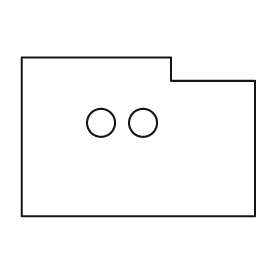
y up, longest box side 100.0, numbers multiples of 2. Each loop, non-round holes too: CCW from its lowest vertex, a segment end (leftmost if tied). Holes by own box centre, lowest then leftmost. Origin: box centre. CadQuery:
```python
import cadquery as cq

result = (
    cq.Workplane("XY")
    .moveTo(-50.0, -34.0)
    .lineTo(50.0, -34.0)
    .lineTo(50.0, 24.0)
    .lineTo(14.0, 24.0)
    .lineTo(14.0, 34.0)
    .lineTo(-50.0, 34.0)
    .close()
    .moveTo(-16.0, 6.0)
    .circle(6.0)
    .moveTo(2.0, 6.0)
    .circle(6.0)
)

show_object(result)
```